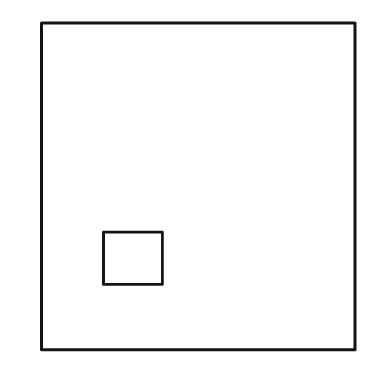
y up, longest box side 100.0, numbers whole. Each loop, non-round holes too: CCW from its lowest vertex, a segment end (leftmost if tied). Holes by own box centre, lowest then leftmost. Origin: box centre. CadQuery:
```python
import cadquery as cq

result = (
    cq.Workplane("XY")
    .moveTo(-48.0, -50.0)
    .lineTo(48.0, -50.0)
    .lineTo(48.0, 50.0)
    .lineTo(-48.0, 50.0)
    .close()
    .moveTo(-29.0, -30.0)
    .lineTo(-11.0, -30.0)
    .lineTo(-11.0, -14.0)
    .lineTo(-29.0, -14.0)
    .close()
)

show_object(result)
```